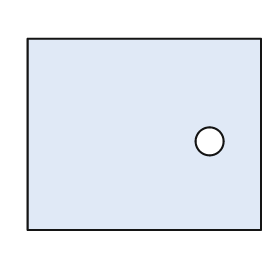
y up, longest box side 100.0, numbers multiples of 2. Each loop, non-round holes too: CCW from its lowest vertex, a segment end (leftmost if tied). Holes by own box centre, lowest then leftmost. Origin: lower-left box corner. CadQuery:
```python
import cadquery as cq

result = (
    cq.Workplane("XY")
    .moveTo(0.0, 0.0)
    .lineTo(100.0, 0.0)
    .lineTo(100.0, 82.0)
    .lineTo(0.0, 82.0)
    .close()
    .moveTo(78.0, 38.0)
    .circle(6.0)
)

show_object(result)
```